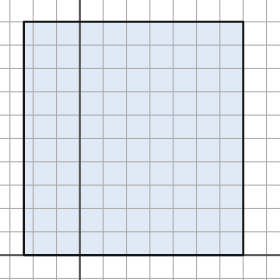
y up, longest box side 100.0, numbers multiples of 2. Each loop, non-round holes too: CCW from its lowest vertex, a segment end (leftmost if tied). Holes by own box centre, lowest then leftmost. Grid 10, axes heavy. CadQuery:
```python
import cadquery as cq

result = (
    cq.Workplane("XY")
    .moveTo(-24.0, 0.0)
    .lineTo(70.0, 0.0)
    .lineTo(70.0, 100.0)
    .lineTo(-24.0, 100.0)
    .close()
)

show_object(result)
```